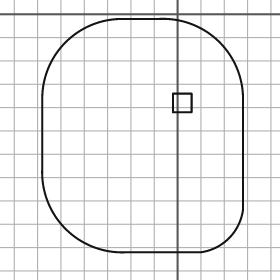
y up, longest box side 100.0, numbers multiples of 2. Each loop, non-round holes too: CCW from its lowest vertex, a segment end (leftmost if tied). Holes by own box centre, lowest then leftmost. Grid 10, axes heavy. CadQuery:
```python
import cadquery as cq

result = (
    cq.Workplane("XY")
    .moveTo(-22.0, -102.0)
    .lineTo(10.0, -102.0)
    .threePointArc((22.0, -96.0), (28.0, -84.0))
    .lineTo(28.0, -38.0)
    .threePointArc((18.0, -12.0), (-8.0, -2.0))
    .lineTo(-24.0, -2.0)
    .threePointArc((-48.0, -12.0), (-58.0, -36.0))
    .lineTo(-58.0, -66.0)
    .threePointArc((-48.0, -92.0), (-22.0, -102.0))
    .close()
    .moveTo(-2.0, -42.0)
    .lineTo(6.0, -42.0)
    .lineTo(6.0, -34.0)
    .lineTo(-2.0, -34.0)
    .close()
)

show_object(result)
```